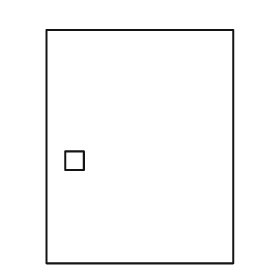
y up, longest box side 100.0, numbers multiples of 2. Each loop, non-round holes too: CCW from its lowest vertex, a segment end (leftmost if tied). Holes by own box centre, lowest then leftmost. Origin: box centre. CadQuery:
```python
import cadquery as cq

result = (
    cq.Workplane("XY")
    .moveTo(-40.0, -50.0)
    .lineTo(40.0, -50.0)
    .lineTo(40.0, 50.0)
    .lineTo(-40.0, 50.0)
    .close()
    .moveTo(-32.0, -10.0)
    .lineTo(-24.0, -10.0)
    .lineTo(-24.0, -2.0)
    .lineTo(-32.0, -2.0)
    .close()
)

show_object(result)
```